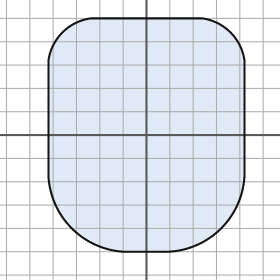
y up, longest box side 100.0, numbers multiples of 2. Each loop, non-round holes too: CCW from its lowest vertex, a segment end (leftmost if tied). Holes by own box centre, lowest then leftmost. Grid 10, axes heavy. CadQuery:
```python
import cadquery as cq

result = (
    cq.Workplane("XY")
    .moveTo(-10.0, -50.0)
    .lineTo(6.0, -50.0)
    .threePointArc((32.0, -40.0), (42.0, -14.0))
    .lineTo(42.0, 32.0)
    .threePointArc((36.0, 44.0), (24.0, 50.0))
    .lineTo(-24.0, 50.0)
    .threePointArc((-36.0, 44.0), (-42.0, 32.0))
    .lineTo(-42.0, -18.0)
    .threePointArc((-32.0, -40.0), (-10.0, -50.0))
    .close()
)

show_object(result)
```